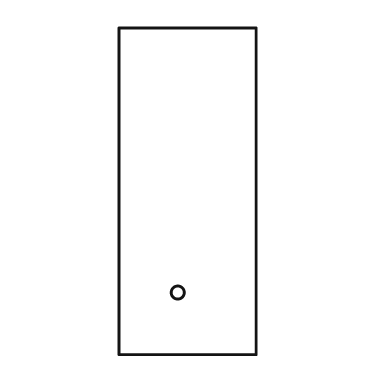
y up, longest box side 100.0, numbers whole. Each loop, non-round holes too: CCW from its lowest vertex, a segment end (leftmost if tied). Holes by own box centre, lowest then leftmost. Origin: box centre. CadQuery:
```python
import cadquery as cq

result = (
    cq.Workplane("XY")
    .moveTo(-21.0, -50.0)
    .lineTo(21.0, -50.0)
    .lineTo(21.0, 50.0)
    .lineTo(-21.0, 50.0)
    .close()
    .moveTo(-3.0, -31.0)
    .circle(2.0)
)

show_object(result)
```